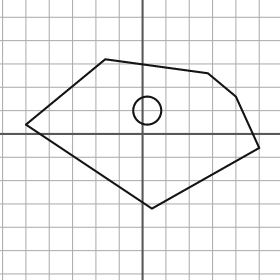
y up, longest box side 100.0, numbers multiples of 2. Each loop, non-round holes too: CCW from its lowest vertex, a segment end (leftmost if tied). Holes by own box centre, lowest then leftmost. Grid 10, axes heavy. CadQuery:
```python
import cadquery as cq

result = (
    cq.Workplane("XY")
    .moveTo(4.0, -32.0)
    .lineTo(50.0, -6.0)
    .lineTo(40.0, 16.0)
    .lineTo(28.0, 26.0)
    .lineTo(-16.0, 32.0)
    .lineTo(-50.0, 4.0)
    .close()
    .moveTo(2.0, 10.0)
    .circle(6.0)
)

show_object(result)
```